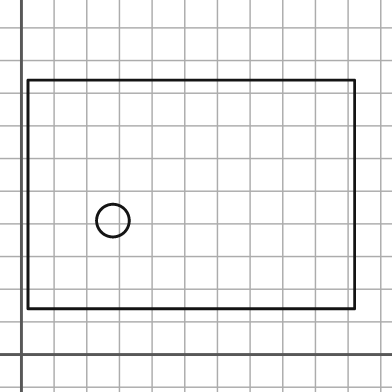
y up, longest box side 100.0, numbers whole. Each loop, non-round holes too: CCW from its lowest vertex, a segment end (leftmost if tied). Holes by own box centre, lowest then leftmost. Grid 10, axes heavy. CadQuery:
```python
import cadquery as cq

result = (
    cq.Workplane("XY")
    .moveTo(2.0, 14.0)
    .lineTo(102.0, 14.0)
    .lineTo(102.0, 84.0)
    .lineTo(2.0, 84.0)
    .close()
    .moveTo(28.0, 41.0)
    .circle(5.0)
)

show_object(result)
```